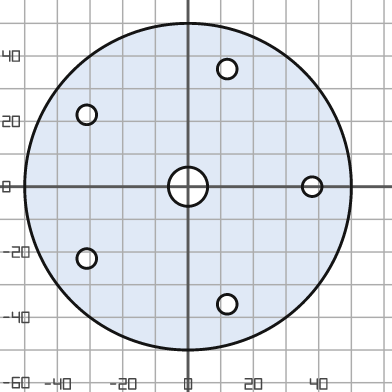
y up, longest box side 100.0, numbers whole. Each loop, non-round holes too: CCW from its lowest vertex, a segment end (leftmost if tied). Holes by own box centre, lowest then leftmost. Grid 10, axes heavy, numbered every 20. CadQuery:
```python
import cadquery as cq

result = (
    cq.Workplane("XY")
    .moveTo(0.0, 0.0)
    .circle(50.0)
    .moveTo(12.0, -36.0)
    .circle(3.0)
    .moveTo(-31.0, -22.0)
    .circle(3.0)
    .moveTo(0.0, 0.0)
    .circle(6.0)
    .moveTo(38.0, 0.0)
    .circle(3.0)
    .moveTo(-31.0, 22.0)
    .circle(3.0)
    .moveTo(12.0, 36.0)
    .circle(3.0)
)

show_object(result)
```